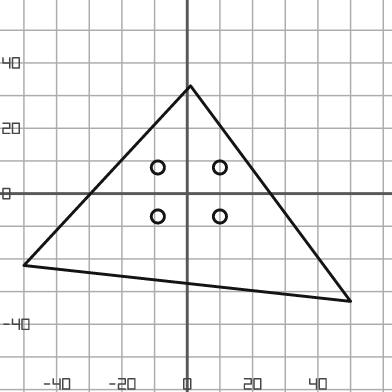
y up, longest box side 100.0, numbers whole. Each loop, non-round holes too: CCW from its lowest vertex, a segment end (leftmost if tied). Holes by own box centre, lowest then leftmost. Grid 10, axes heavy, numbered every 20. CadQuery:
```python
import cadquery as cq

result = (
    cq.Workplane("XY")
    .moveTo(50.0, -33.0)
    .lineTo(1.0, 33.0)
    .lineTo(-50.0, -22.0)
    .close()
    .moveTo(-9.0, -7.0)
    .circle(2.0)
    .moveTo(10.0, -7.0)
    .circle(2.0)
    .moveTo(-9.0, 8.0)
    .circle(2.0)
    .moveTo(10.0, 8.0)
    .circle(2.0)
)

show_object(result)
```